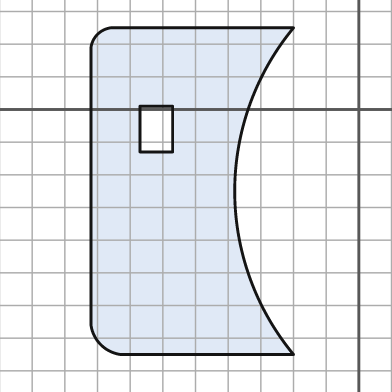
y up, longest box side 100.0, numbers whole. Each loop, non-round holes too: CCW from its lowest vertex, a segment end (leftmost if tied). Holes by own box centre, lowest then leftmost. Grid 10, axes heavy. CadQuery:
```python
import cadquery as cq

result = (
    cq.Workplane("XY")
    .moveTo(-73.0, -75.0)
    .lineTo(-20.0, -75.0)
    .threePointArc((-38.0, -25.0), (-20.0, 25.0))
    .lineTo(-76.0, 25.0)
    .threePointArc((-80.0, 23.0), (-82.0, 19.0))
    .lineTo(-82.0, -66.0)
    .threePointArc((-79.0, -72.0), (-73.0, -75.0))
    .close()
    .moveTo(-67.0, -13.0)
    .lineTo(-57.0, -13.0)
    .lineTo(-57.0, 1.0)
    .lineTo(-67.0, 1.0)
    .close()
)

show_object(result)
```